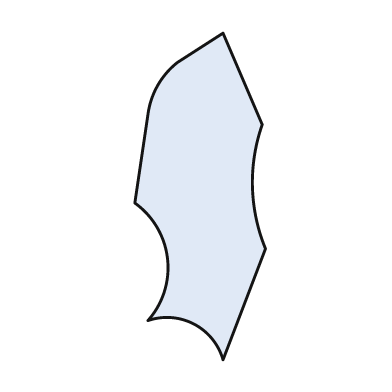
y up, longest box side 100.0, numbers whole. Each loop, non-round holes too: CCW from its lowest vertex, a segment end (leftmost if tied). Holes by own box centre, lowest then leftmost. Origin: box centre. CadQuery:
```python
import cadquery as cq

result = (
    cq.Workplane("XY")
    .moveTo(7.0, -50.0)
    .lineTo(20.0, -16.0)
    .threePointArc((16.0, 3.0), (19.0, 22.0))
    .lineTo(7.0, 50.0)
    .lineTo(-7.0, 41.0)
    .threePointArc((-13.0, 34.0), (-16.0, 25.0))
    .lineTo(-20.0, -2.0)
    .threePointArc((-10.0, -19.0), (-16.0, -38.0))
    .threePointArc((-2.0, -39.0), (7.0, -50.0))
    .close()
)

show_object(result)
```